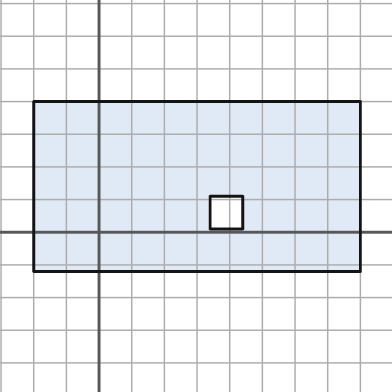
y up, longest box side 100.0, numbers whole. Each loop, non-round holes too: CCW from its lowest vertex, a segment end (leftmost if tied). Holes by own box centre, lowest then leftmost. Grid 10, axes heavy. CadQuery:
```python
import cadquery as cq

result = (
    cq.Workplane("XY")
    .moveTo(-20.0, -12.0)
    .lineTo(80.0, -12.0)
    .lineTo(80.0, 40.0)
    .lineTo(-20.0, 40.0)
    .close()
    .moveTo(34.0, 1.0)
    .lineTo(44.0, 1.0)
    .lineTo(44.0, 11.0)
    .lineTo(34.0, 11.0)
    .close()
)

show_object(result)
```